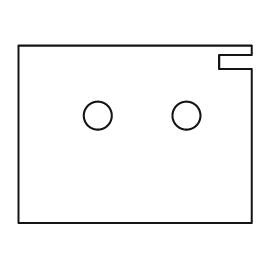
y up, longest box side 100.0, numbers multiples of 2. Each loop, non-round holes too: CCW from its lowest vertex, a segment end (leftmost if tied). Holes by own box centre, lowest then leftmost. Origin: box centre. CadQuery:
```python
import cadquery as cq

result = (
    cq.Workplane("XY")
    .moveTo(-50.0, -38.0)
    .lineTo(50.0, -38.0)
    .lineTo(50.0, 28.0)
    .lineTo(36.0, 28.0)
    .lineTo(36.0, 34.0)
    .lineTo(50.0, 34.0)
    .lineTo(50.0, 38.0)
    .lineTo(-50.0, 38.0)
    .close()
    .moveTo(-16.0, 8.0)
    .circle(6.0)
    .moveTo(22.0, 8.0)
    .circle(6.0)
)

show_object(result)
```